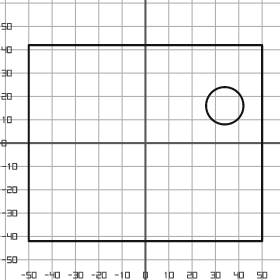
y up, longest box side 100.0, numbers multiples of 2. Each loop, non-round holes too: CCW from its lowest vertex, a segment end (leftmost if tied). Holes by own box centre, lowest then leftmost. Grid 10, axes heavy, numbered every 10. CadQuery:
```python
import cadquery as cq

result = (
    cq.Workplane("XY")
    .moveTo(-50.0, -42.0)
    .lineTo(50.0, -42.0)
    .lineTo(50.0, 42.0)
    .lineTo(-50.0, 42.0)
    .close()
    .moveTo(34.0, 16.0)
    .circle(8.0)
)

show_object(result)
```